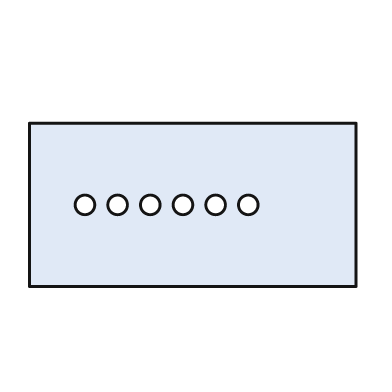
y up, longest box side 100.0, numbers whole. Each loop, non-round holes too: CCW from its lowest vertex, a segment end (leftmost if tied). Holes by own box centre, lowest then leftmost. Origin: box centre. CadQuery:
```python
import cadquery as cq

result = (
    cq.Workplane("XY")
    .moveTo(-50.0, -25.0)
    .lineTo(50.0, -25.0)
    .lineTo(50.0, 25.0)
    .lineTo(-50.0, 25.0)
    .close()
    .moveTo(-33.0, 0.0)
    .circle(3.0)
    .moveTo(-23.0, 0.0)
    .circle(3.0)
    .moveTo(-13.0, 0.0)
    .circle(3.0)
    .moveTo(-3.0, 0.0)
    .circle(3.0)
    .moveTo(7.0, 0.0)
    .circle(3.0)
    .moveTo(17.0, 0.0)
    .circle(3.0)
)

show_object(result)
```